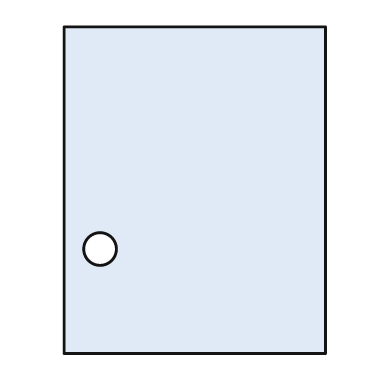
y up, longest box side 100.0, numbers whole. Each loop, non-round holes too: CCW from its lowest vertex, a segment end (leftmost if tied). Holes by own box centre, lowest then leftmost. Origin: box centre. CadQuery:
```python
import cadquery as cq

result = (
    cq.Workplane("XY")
    .moveTo(-40.0, -50.0)
    .lineTo(40.0, -50.0)
    .lineTo(40.0, 50.0)
    .lineTo(-40.0, 50.0)
    .close()
    .moveTo(-29.0, -18.0)
    .circle(5.0)
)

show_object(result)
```